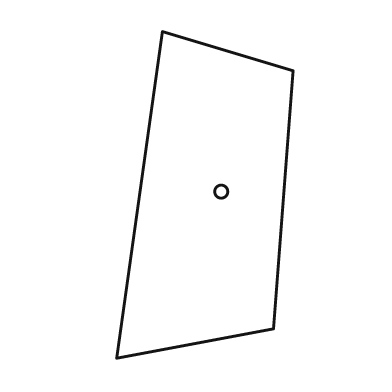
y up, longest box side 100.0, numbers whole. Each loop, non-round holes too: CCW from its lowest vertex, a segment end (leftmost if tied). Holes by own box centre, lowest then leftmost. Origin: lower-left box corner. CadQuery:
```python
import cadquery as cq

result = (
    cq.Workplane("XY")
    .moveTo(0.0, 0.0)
    .lineTo(48.0, 9.0)
    .lineTo(54.0, 88.0)
    .lineTo(14.0, 100.0)
    .close()
    .moveTo(32.0, 51.0)
    .circle(2.0)
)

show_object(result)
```